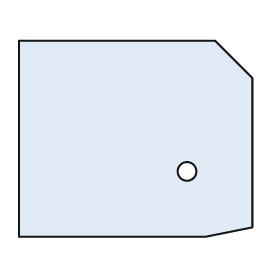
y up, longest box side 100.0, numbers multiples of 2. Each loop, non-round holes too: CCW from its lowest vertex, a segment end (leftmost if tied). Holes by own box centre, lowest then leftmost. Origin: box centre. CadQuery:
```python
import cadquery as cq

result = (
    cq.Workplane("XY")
    .moveTo(-50.0, -42.0)
    .lineTo(30.0, -42.0)
    .lineTo(50.0, -38.0)
    .lineTo(50.0, 26.0)
    .lineTo(34.0, 42.0)
    .lineTo(-50.0, 42.0)
    .close()
    .moveTo(22.0, -14.0)
    .circle(4.0)
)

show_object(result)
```